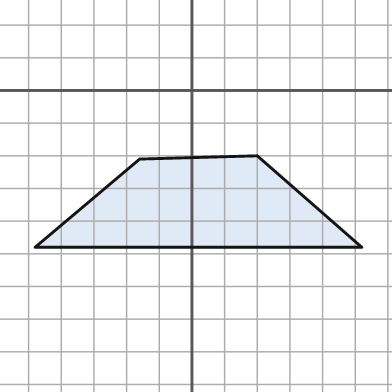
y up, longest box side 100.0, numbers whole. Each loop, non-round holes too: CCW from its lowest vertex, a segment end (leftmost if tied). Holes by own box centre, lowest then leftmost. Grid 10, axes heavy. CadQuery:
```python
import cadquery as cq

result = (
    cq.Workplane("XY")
    .moveTo(-48.0, -48.0)
    .lineTo(52.0, -48.0)
    .lineTo(20.0, -20.0)
    .lineTo(-16.0, -21.0)
    .close()
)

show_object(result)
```